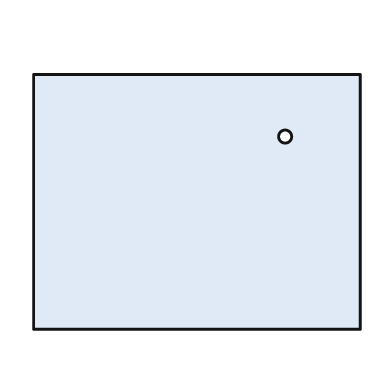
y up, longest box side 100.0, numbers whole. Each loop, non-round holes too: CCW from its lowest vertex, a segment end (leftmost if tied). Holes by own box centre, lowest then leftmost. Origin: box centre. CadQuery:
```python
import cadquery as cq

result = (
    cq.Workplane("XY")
    .moveTo(-50.0, -39.0)
    .lineTo(50.0, -39.0)
    .lineTo(50.0, 39.0)
    .lineTo(-50.0, 39.0)
    .close()
    .moveTo(27.0, 20.0)
    .circle(2.0)
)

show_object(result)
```